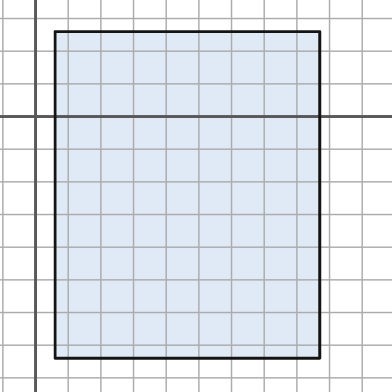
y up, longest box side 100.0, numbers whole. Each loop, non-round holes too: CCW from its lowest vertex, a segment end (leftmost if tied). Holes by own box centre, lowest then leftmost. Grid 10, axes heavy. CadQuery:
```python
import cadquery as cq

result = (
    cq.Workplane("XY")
    .moveTo(6.0, -74.0)
    .lineTo(87.0, -74.0)
    .lineTo(87.0, 26.0)
    .lineTo(6.0, 26.0)
    .close()
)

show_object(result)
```